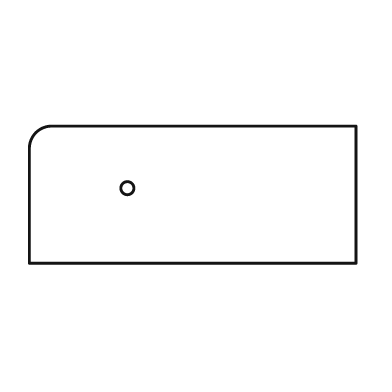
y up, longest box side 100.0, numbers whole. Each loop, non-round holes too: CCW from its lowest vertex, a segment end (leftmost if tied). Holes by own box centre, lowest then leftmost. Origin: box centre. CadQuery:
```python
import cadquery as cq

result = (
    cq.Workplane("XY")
    .moveTo(-50.0, -21.0)
    .lineTo(50.0, -21.0)
    .lineTo(50.0, 21.0)
    .lineTo(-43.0, 21.0)
    .threePointArc((-48.0, 19.0), (-50.0, 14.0))
    .close()
    .moveTo(-20.0, 2.0)
    .circle(2.0)
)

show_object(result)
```